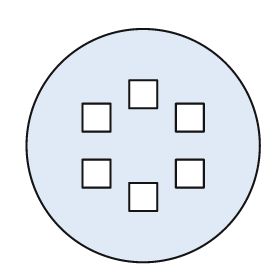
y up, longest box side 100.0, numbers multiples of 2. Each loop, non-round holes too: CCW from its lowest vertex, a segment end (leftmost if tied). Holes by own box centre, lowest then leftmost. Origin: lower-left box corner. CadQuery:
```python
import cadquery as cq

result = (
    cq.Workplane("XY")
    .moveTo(50.0, 50.0)
    .circle(50.0)
    .moveTo(44.0, 22.0)
    .lineTo(56.0, 22.0)
    .lineTo(56.0, 34.0)
    .lineTo(44.0, 34.0)
    .close()
    .moveTo(24.0, 32.0)
    .lineTo(36.0, 32.0)
    .lineTo(36.0, 44.0)
    .lineTo(24.0, 44.0)
    .close()
    .moveTo(64.0, 32.0)
    .lineTo(76.0, 32.0)
    .lineTo(76.0, 44.0)
    .lineTo(64.0, 44.0)
    .close()
    .moveTo(24.0, 56.0)
    .lineTo(36.0, 56.0)
    .lineTo(36.0, 68.0)
    .lineTo(24.0, 68.0)
    .close()
    .moveTo(64.0, 56.0)
    .lineTo(76.0, 56.0)
    .lineTo(76.0, 68.0)
    .lineTo(64.0, 68.0)
    .close()
    .moveTo(44.0, 66.0)
    .lineTo(56.0, 66.0)
    .lineTo(56.0, 78.0)
    .lineTo(44.0, 78.0)
    .close()
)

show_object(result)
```